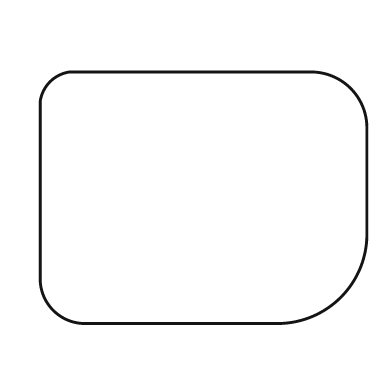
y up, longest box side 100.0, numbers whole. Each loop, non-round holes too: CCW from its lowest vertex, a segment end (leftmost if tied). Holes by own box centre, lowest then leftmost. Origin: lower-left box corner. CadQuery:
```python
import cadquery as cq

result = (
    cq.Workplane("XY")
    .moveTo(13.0, 0.0)
    .lineTo(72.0, 0.0)
    .threePointArc((92.0, 8.0), (100.0, 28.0))
    .lineTo(100.0, 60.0)
    .threePointArc((95.0, 72.0), (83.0, 77.0))
    .lineTo(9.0, 77.0)
    .threePointArc((3.0, 74.0), (0.0, 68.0))
    .lineTo(0.0, 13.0)
    .threePointArc((4.0, 4.0), (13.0, 0.0))
    .close()
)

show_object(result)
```